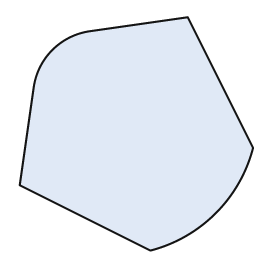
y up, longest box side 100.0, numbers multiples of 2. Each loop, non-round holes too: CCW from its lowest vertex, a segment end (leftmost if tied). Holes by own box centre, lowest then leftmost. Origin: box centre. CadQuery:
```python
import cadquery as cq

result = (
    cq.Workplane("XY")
    .moveTo(6.0, -50.0)
    .threePointArc((34.0, -34.0), (50.0, -6.0))
    .lineTo(22.0, 50.0)
    .lineTo(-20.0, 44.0)
    .threePointArc((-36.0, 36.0), (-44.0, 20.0))
    .lineTo(-50.0, -22.0)
    .close()
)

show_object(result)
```